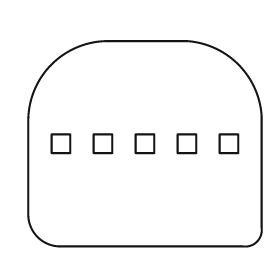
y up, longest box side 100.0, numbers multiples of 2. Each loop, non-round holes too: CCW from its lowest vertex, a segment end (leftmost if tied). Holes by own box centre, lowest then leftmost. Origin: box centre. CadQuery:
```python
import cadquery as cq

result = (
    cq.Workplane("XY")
    .moveTo(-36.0, -44.0)
    .lineTo(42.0, -44.0)
    .threePointArc((48.0, -42.0), (50.0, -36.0))
    .lineTo(50.0, 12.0)
    .threePointArc((40.0, 34.0), (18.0, 44.0))
    .lineTo(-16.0, 44.0)
    .threePointArc((-40.0, 34.0), (-50.0, 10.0))
    .lineTo(-50.0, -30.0)
    .threePointArc((-46.0, -40.0), (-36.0, -44.0))
    .close()
    .moveTo(-40.0, -4.0)
    .lineTo(-32.0, -4.0)
    .lineTo(-32.0, 4.0)
    .lineTo(-40.0, 4.0)
    .close()
    .moveTo(-22.0, -4.0)
    .lineTo(-14.0, -4.0)
    .lineTo(-14.0, 4.0)
    .lineTo(-22.0, 4.0)
    .close()
    .moveTo(-4.0, -4.0)
    .lineTo(4.0, -4.0)
    .lineTo(4.0, 4.0)
    .lineTo(-4.0, 4.0)
    .close()
    .moveTo(14.0, -4.0)
    .lineTo(22.0, -4.0)
    .lineTo(22.0, 4.0)
    .lineTo(14.0, 4.0)
    .close()
    .moveTo(32.0, -4.0)
    .lineTo(40.0, -4.0)
    .lineTo(40.0, 4.0)
    .lineTo(32.0, 4.0)
    .close()
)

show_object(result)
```